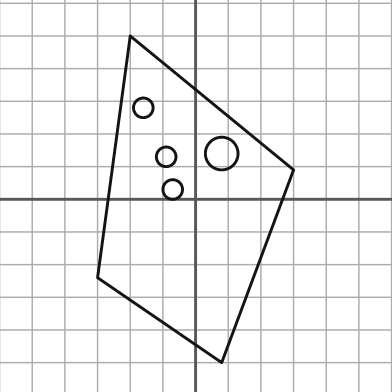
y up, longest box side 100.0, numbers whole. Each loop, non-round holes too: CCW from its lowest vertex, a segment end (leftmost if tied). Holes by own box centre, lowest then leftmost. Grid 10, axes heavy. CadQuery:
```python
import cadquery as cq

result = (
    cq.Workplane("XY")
    .moveTo(8.0, -50.0)
    .lineTo(30.0, 9.0)
    .lineTo(-20.0, 50.0)
    .lineTo(-30.0, -24.0)
    .close()
    .moveTo(-7.0, 3.0)
    .circle(3.0)
    .moveTo(-9.0, 13.0)
    .circle(3.0)
    .moveTo(8.0, 14.0)
    .circle(5.0)
    .moveTo(-16.0, 28.0)
    .circle(3.0)
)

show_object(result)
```